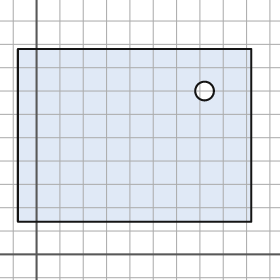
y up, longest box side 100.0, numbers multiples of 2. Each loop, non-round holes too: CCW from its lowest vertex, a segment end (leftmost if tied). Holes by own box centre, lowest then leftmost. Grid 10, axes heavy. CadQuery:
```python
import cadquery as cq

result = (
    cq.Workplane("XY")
    .moveTo(-8.0, 14.0)
    .lineTo(92.0, 14.0)
    .lineTo(92.0, 88.0)
    .lineTo(-8.0, 88.0)
    .close()
    .moveTo(72.0, 70.0)
    .circle(4.0)
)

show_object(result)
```